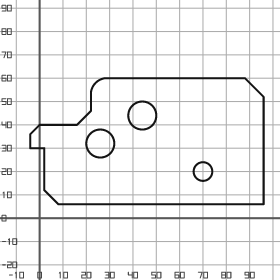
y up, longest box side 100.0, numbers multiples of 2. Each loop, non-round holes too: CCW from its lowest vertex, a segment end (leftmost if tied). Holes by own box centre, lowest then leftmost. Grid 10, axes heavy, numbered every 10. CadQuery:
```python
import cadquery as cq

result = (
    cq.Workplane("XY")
    .moveTo(8.0, 6.0)
    .lineTo(96.0, 6.0)
    .lineTo(96.0, 52.0)
    .lineTo(88.0, 60.0)
    .lineTo(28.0, 60.0)
    .threePointArc((24.0, 58.0), (22.0, 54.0))
    .lineTo(22.0, 46.0)
    .lineTo(16.0, 40.0)
    .lineTo(0.0, 40.0)
    .lineTo(-4.0, 36.0)
    .lineTo(-4.0, 30.0)
    .lineTo(2.0, 30.0)
    .lineTo(2.0, 12.0)
    .close()
    .moveTo(70.0, 20.0)
    .circle(4.0)
    .moveTo(26.0, 32.0)
    .circle(6.0)
    .moveTo(44.0, 44.0)
    .circle(6.0)
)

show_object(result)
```